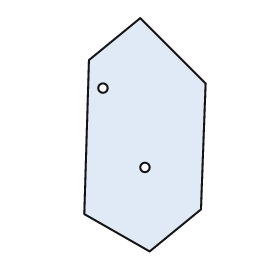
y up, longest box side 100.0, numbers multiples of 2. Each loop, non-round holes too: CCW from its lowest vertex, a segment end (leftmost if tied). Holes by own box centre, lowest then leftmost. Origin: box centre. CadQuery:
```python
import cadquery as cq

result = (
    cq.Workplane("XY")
    .moveTo(2.0, -50.0)
    .lineTo(24.0, -32.0)
    .lineTo(26.0, 22.0)
    .lineTo(-2.0, 50.0)
    .lineTo(-24.0, 32.0)
    .lineTo(-26.0, -34.0)
    .close()
    .moveTo(0.0, -14.0)
    .circle(2.0)
    .moveTo(-18.0, 20.0)
    .circle(2.0)
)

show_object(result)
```